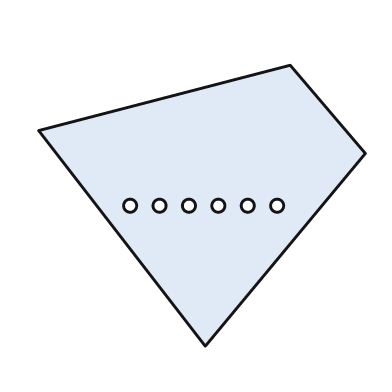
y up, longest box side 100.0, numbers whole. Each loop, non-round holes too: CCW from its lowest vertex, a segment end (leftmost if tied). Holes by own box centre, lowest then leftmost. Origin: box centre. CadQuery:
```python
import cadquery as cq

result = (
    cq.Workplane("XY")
    .moveTo(1.0, -43.0)
    .lineTo(50.0, 16.0)
    .lineTo(27.0, 43.0)
    .lineTo(-50.0, 23.0)
    .close()
    .moveTo(-22.0, 0.0)
    .circle(2.0)
    .moveTo(-13.0, 0.0)
    .circle(2.0)
    .moveTo(-4.0, 0.0)
    .circle(2.0)
    .moveTo(5.0, 0.0)
    .circle(2.0)
    .moveTo(14.0, 0.0)
    .circle(2.0)
    .moveTo(23.0, 0.0)
    .circle(2.0)
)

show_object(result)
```